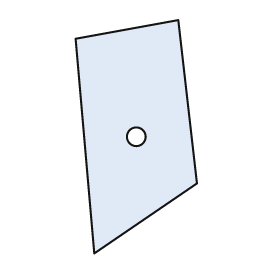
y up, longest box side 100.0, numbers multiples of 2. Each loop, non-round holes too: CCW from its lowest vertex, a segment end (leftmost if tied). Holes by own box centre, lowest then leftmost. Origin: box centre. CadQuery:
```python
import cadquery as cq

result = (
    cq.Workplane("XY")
    .moveTo(-18.0, -50.0)
    .lineTo(26.0, -20.0)
    .lineTo(18.0, 50.0)
    .lineTo(-26.0, 42.0)
    .close()
    .moveTo(0.0, 0.0)
    .circle(4.0)
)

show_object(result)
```